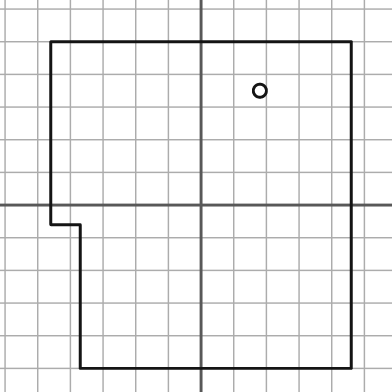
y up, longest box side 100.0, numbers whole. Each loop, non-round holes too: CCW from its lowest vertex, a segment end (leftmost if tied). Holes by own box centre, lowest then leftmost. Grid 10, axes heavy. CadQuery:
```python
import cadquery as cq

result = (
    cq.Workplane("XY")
    .moveTo(-37.0, -50.0)
    .lineTo(46.0, -50.0)
    .lineTo(46.0, 50.0)
    .lineTo(-46.0, 50.0)
    .lineTo(-46.0, -6.0)
    .lineTo(-37.0, -6.0)
    .close()
    .moveTo(18.0, 35.0)
    .circle(2.0)
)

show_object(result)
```